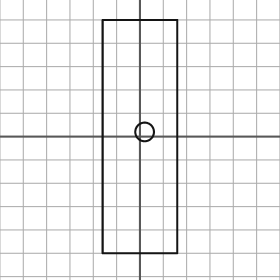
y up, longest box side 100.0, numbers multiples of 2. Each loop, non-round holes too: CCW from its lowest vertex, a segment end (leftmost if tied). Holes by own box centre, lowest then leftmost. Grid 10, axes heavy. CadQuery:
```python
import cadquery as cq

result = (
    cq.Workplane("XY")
    .moveTo(-16.0, -50.0)
    .lineTo(16.0, -50.0)
    .lineTo(16.0, 50.0)
    .lineTo(-16.0, 50.0)
    .close()
    .moveTo(2.0, 2.0)
    .circle(4.0)
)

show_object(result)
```